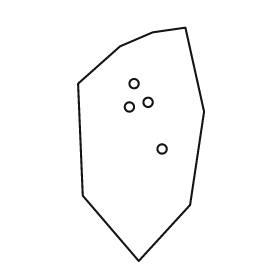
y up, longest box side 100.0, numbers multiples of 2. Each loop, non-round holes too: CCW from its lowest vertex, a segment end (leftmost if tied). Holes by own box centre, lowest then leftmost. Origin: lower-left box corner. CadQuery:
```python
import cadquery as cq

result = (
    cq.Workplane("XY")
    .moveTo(26.0, 0.0)
    .lineTo(48.0, 24.0)
    .lineTo(54.0, 64.0)
    .lineTo(46.0, 100.0)
    .lineTo(32.0, 98.0)
    .lineTo(18.0, 92.0)
    .lineTo(0.0, 76.0)
    .lineTo(2.0, 28.0)
    .close()
    .moveTo(36.0, 48.0)
    .circle(2.0)
    .moveTo(22.0, 66.0)
    .circle(2.0)
    .moveTo(30.0, 68.0)
    .circle(2.0)
    .moveTo(24.0, 76.0)
    .circle(2.0)
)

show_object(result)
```